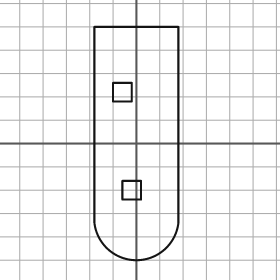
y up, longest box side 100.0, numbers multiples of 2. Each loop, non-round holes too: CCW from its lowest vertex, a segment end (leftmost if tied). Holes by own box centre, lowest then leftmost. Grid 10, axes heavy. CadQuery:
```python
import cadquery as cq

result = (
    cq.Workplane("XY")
    .moveTo(-18.0, -34.0)
    .threePointArc((0.0, -50.0), (18.0, -34.0))
    .lineTo(18.0, 50.0)
    .lineTo(-18.0, 50.0)
    .close()
    .moveTo(-6.0, -24.0)
    .lineTo(2.0, -24.0)
    .lineTo(2.0, -16.0)
    .lineTo(-6.0, -16.0)
    .close()
    .moveTo(-10.0, 18.0)
    .lineTo(-2.0, 18.0)
    .lineTo(-2.0, 26.0)
    .lineTo(-10.0, 26.0)
    .close()
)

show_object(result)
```